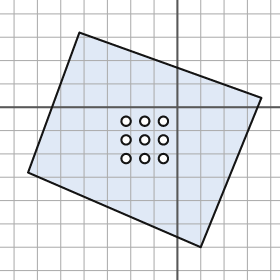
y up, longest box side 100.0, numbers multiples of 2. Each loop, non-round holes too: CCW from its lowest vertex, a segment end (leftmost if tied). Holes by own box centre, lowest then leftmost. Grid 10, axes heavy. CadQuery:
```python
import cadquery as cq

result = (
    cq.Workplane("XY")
    .moveTo(10.0, -60.0)
    .lineTo(36.0, 4.0)
    .lineTo(-42.0, 32.0)
    .lineTo(-64.0, -28.0)
    .close()
    .moveTo(-22.0, -22.0)
    .circle(2.0)
    .moveTo(-14.0, -22.0)
    .circle(2.0)
    .moveTo(-6.0, -22.0)
    .circle(2.0)
    .moveTo(-22.0, -14.0)
    .circle(2.0)
    .moveTo(-14.0, -14.0)
    .circle(2.0)
    .moveTo(-6.0, -14.0)
    .circle(2.0)
    .moveTo(-22.0, -6.0)
    .circle(2.0)
    .moveTo(-14.0, -6.0)
    .circle(2.0)
    .moveTo(-6.0, -6.0)
    .circle(2.0)
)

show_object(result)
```